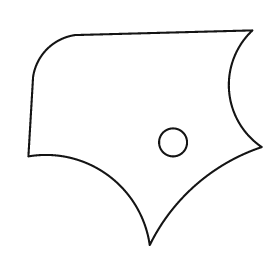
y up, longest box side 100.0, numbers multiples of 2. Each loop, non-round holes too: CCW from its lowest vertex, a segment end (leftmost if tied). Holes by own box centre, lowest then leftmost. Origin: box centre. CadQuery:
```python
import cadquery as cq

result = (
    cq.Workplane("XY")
    .moveTo(2.0, -46.0)
    .threePointArc((22.0, -20.0), (50.0, -4.0))
    .threePointArc((36.0, 20.0), (46.0, 46.0))
    .lineTo(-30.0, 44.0)
    .threePointArc((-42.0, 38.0), (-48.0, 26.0))
    .lineTo(-50.0, -8.0)
    .threePointArc((-16.0, -16.0), (2.0, -46.0))
    .close()
    .moveTo(12.0, -2.0)
    .circle(6.0)
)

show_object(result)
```